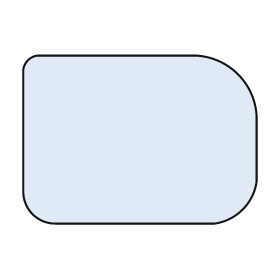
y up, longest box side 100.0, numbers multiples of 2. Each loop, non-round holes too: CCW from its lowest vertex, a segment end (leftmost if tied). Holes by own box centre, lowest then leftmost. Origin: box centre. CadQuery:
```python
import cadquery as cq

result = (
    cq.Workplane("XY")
    .moveTo(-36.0, -36.0)
    .lineTo(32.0, -36.0)
    .threePointArc((44.0, -30.0), (50.0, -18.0))
    .lineTo(50.0, 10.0)
    .threePointArc((42.0, 28.0), (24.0, 36.0))
    .lineTo(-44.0, 36.0)
    .threePointArc((-48.0, 34.0), (-50.0, 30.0))
    .lineTo(-50.0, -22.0)
    .threePointArc((-46.0, -32.0), (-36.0, -36.0))
    .close()
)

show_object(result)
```